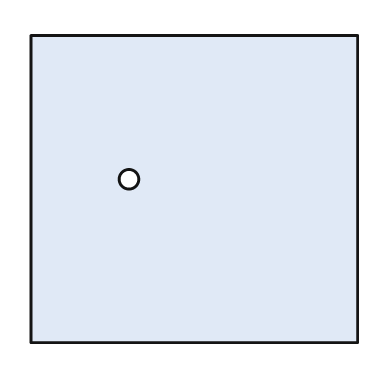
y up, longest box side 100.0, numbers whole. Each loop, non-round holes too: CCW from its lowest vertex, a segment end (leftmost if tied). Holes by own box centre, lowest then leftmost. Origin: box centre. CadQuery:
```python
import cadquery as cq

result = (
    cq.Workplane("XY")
    .moveTo(-50.0, -47.0)
    .lineTo(50.0, -47.0)
    .lineTo(50.0, 47.0)
    .lineTo(-50.0, 47.0)
    .close()
    .moveTo(-20.0, 3.0)
    .circle(3.0)
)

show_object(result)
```